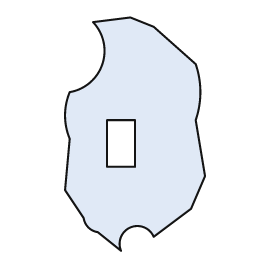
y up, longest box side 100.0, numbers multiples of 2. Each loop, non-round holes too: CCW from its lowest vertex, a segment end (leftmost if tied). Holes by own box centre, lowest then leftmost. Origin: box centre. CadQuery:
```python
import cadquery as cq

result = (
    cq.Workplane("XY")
    .moveTo(-6.0, -50.0)
    .threePointArc((-2.0, -40.0), (8.0, -44.0))
    .lineTo(24.0, -32.0)
    .lineTo(30.0, -18.0)
    .lineTo(26.0, 6.0)
    .threePointArc((28.0, 18.0), (26.0, 30.0))
    .lineTo(8.0, 46.0)
    .lineTo(-2.0, 50.0)
    .lineTo(-18.0, 48.0)
    .threePointArc((-14.0, 30.0), (-28.0, 18.0))
    .threePointArc((-30.0, 8.0), (-28.0, -2.0))
    .lineTo(-30.0, -24.0)
    .lineTo(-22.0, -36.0)
    .threePointArc((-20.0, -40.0), (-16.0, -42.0))
    .close()
    .moveTo(-12.0, -14.0)
    .lineTo(0.0, -14.0)
    .lineTo(0.0, 6.0)
    .lineTo(-12.0, 6.0)
    .close()
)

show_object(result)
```